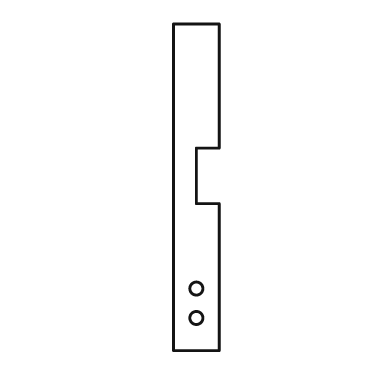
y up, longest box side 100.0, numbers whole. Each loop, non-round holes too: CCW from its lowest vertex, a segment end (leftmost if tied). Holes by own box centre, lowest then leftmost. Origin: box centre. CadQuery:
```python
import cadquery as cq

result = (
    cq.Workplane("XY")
    .moveTo(-7.0, -50.0)
    .lineTo(7.0, -50.0)
    .lineTo(7.0, -5.0)
    .lineTo(0.0, -5.0)
    .lineTo(0.0, 12.0)
    .lineTo(7.0, 12.0)
    .lineTo(7.0, 50.0)
    .lineTo(-7.0, 50.0)
    .close()
    .moveTo(0.0, -40.0)
    .circle(2.0)
    .moveTo(0.0, -31.0)
    .circle(2.0)
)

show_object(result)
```